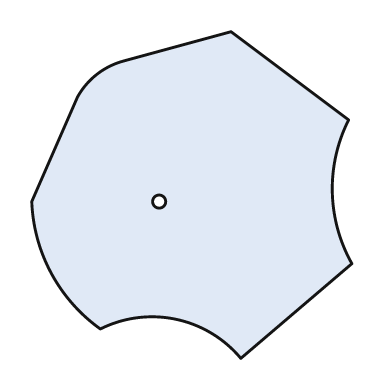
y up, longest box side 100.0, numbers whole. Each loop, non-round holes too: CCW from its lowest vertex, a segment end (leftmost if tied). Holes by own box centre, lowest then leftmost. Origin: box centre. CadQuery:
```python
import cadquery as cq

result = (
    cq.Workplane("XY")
    .moveTo(15.0, -50.0)
    .lineTo(49.0, -21.0)
    .threePointArc((43.0, 1.0), (48.0, 23.0))
    .lineTo(12.0, 50.0)
    .lineTo(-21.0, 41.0)
    .threePointArc((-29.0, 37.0), (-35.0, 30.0))
    .lineTo(-49.0, -2.0)
    .threePointArc((-43.0, -24.0), (-28.0, -41.0))
    .threePointArc((-5.0, -38.0), (15.0, -50.0))
    .close()
    .moveTo(-10.0, -2.0)
    .circle(2.0)
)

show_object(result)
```